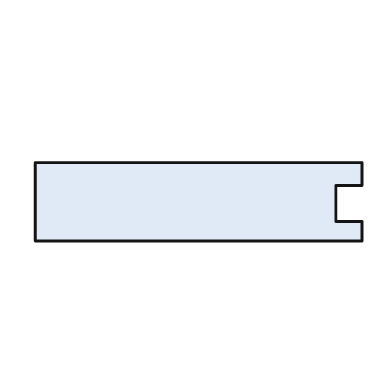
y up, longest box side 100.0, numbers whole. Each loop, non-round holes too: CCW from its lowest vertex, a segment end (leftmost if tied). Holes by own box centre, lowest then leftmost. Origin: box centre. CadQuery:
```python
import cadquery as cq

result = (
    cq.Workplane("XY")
    .moveTo(-50.0, -12.0)
    .lineTo(50.0, -12.0)
    .lineTo(50.0, -6.0)
    .lineTo(42.0, -6.0)
    .lineTo(42.0, 5.0)
    .lineTo(50.0, 5.0)
    .lineTo(50.0, 12.0)
    .lineTo(-50.0, 12.0)
    .close()
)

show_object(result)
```